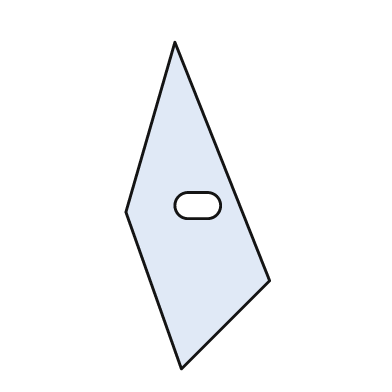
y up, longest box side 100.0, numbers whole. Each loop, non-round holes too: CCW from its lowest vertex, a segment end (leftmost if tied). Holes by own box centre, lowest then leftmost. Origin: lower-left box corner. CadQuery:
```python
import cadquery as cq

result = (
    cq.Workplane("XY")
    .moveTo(17.0, 0.0)
    .lineTo(44.0, 27.0)
    .lineTo(15.0, 100.0)
    .lineTo(0.0, 48.0)
    .close()
    .moveTo(19.0, 46.0)
    .lineTo(25.0, 46.0)
    .threePointArc((29.0, 50.0), (25.0, 54.0))
    .lineTo(19.0, 54.0)
    .threePointArc((15.0, 50.0), (19.0, 46.0))
    .close()
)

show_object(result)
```